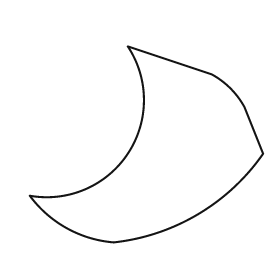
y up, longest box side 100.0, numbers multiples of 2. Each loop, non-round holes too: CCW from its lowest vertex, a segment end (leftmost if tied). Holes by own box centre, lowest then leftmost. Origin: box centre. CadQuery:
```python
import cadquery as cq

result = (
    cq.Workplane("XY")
    .moveTo(-14.0, -42.0)
    .threePointArc((22.0, -30.0), (50.0, -4.0))
    .lineTo(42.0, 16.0)
    .threePointArc((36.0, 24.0), (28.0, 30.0))
    .lineTo(-8.0, 42.0)
    .threePointArc((-8.0, -4.0), (-50.0, -22.0))
    .threePointArc((-34.0, -36.0), (-14.0, -42.0))
    .close()
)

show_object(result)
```